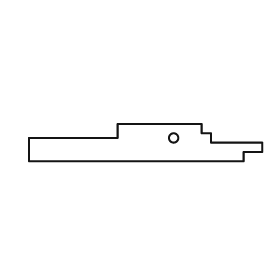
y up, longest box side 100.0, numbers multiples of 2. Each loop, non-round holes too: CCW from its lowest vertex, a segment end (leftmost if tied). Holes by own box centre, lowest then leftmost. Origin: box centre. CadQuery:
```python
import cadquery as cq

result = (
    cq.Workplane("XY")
    .moveTo(-50.0, -8.0)
    .lineTo(42.0, -8.0)
    .lineTo(42.0, -4.0)
    .lineTo(50.0, -4.0)
    .lineTo(50.0, 0.0)
    .lineTo(28.0, 0.0)
    .lineTo(28.0, 4.0)
    .lineTo(24.0, 4.0)
    .lineTo(24.0, 8.0)
    .lineTo(-12.0, 8.0)
    .lineTo(-12.0, 2.0)
    .lineTo(-50.0, 2.0)
    .close()
    .moveTo(12.0, 2.0)
    .circle(2.0)
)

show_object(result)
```